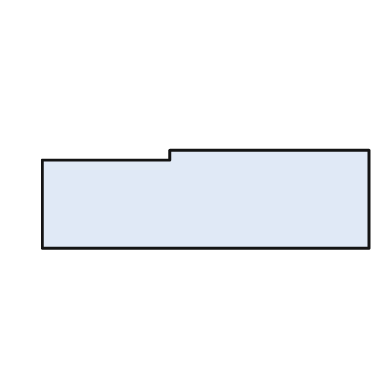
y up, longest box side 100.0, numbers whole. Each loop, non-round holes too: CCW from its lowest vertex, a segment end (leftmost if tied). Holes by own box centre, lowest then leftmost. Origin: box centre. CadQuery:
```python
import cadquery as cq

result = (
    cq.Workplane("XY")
    .moveTo(-50.0, -15.0)
    .lineTo(50.0, -15.0)
    .lineTo(50.0, 15.0)
    .lineTo(-11.0, 15.0)
    .lineTo(-11.0, 12.0)
    .lineTo(-50.0, 12.0)
    .close()
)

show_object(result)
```